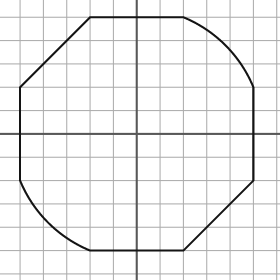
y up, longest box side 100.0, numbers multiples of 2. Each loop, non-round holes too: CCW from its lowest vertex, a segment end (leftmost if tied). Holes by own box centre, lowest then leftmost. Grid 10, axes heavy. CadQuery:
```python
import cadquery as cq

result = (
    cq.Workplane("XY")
    .moveTo(-20.0, -50.0)
    .lineTo(20.0, -50.0)
    .lineTo(50.0, -20.0)
    .lineTo(50.0, 20.0)
    .threePointArc((38.0, 38.0), (20.0, 50.0))
    .lineTo(-20.0, 50.0)
    .lineTo(-50.0, 20.0)
    .lineTo(-50.0, -20.0)
    .threePointArc((-38.0, -38.0), (-20.0, -50.0))
    .close()
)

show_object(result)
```